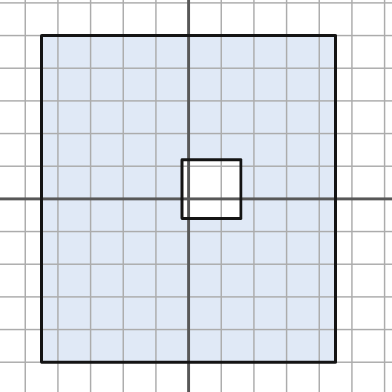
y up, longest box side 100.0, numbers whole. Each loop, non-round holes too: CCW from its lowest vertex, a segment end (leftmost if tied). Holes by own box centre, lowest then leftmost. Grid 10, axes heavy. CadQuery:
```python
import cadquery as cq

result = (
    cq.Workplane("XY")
    .moveTo(-45.0, -50.0)
    .lineTo(45.0, -50.0)
    .lineTo(45.0, 50.0)
    .lineTo(-45.0, 50.0)
    .close()
    .moveTo(-2.0, -6.0)
    .lineTo(16.0, -6.0)
    .lineTo(16.0, 12.0)
    .lineTo(-2.0, 12.0)
    .close()
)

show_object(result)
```